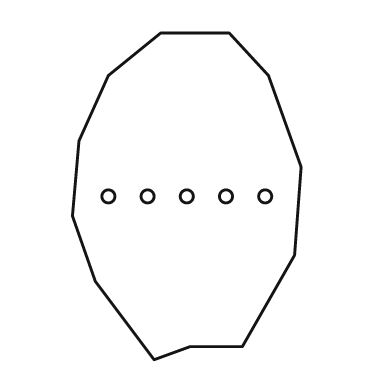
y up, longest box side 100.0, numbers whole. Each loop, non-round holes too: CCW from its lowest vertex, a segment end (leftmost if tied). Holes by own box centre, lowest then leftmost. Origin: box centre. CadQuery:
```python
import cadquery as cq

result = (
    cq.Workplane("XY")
    .moveTo(-10.0, -50.0)
    .lineTo(1.0, -46.0)
    .lineTo(17.0, -46.0)
    .lineTo(33.0, -18.0)
    .lineTo(35.0, 9.0)
    .lineTo(25.0, 37.0)
    .lineTo(13.0, 50.0)
    .lineTo(-8.0, 50.0)
    .lineTo(-24.0, 37.0)
    .lineTo(-33.0, 17.0)
    .lineTo(-35.0, -6.0)
    .lineTo(-28.0, -26.0)
    .close()
    .moveTo(-24.0, 0.0)
    .circle(2.0)
    .moveTo(-12.0, 0.0)
    .circle(2.0)
    .moveTo(0.0, 0.0)
    .circle(2.0)
    .moveTo(12.0, 0.0)
    .circle(2.0)
    .moveTo(24.0, 0.0)
    .circle(2.0)
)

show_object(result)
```